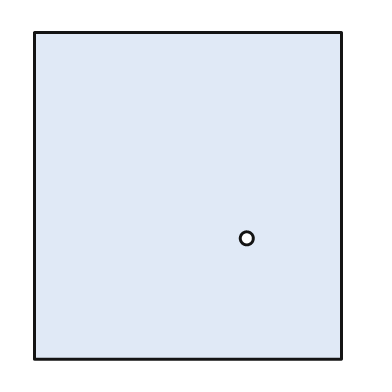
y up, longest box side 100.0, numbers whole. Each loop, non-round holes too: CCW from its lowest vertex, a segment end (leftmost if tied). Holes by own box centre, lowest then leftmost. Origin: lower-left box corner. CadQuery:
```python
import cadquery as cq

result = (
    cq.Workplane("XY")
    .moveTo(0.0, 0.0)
    .lineTo(94.0, 0.0)
    .lineTo(94.0, 100.0)
    .lineTo(0.0, 100.0)
    .close()
    .moveTo(65.0, 37.0)
    .circle(2.0)
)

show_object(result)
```